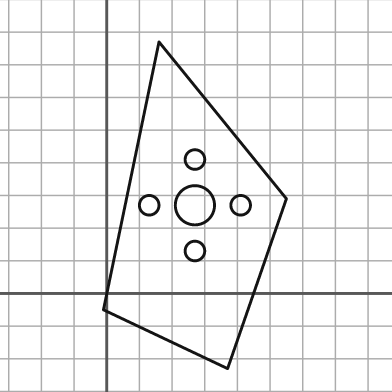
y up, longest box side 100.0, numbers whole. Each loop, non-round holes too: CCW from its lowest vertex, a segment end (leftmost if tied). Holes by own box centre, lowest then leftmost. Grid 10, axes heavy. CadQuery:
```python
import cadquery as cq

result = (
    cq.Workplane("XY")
    .moveTo(37.0, -23.0)
    .lineTo(55.0, 29.0)
    .lineTo(16.0, 77.0)
    .lineTo(-1.0, -5.0)
    .close()
    .moveTo(27.0, 13.0)
    .circle(3.0)
    .moveTo(13.0, 27.0)
    .circle(3.0)
    .moveTo(27.0, 27.0)
    .circle(6.0)
    .moveTo(41.0, 27.0)
    .circle(3.0)
    .moveTo(27.0, 41.0)
    .circle(3.0)
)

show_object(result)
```